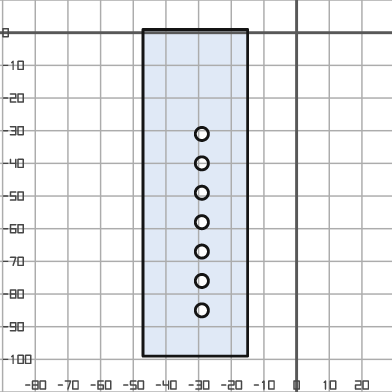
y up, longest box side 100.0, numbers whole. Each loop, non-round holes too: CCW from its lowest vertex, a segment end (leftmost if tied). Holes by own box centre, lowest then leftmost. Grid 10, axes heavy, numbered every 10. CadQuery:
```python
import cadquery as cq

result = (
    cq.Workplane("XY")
    .moveTo(-47.0, -99.0)
    .lineTo(-15.0, -99.0)
    .lineTo(-15.0, 1.0)
    .lineTo(-47.0, 1.0)
    .close()
    .moveTo(-29.0, -85.0)
    .circle(2.0)
    .moveTo(-29.0, -76.0)
    .circle(2.0)
    .moveTo(-29.0, -67.0)
    .circle(2.0)
    .moveTo(-29.0, -58.0)
    .circle(2.0)
    .moveTo(-29.0, -49.0)
    .circle(2.0)
    .moveTo(-29.0, -40.0)
    .circle(2.0)
    .moveTo(-29.0, -31.0)
    .circle(2.0)
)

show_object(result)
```